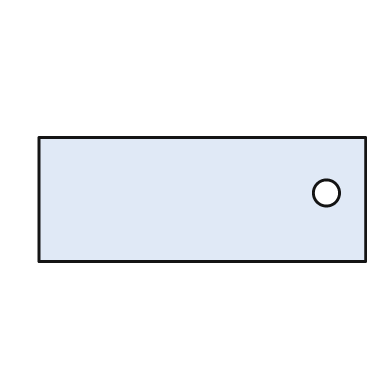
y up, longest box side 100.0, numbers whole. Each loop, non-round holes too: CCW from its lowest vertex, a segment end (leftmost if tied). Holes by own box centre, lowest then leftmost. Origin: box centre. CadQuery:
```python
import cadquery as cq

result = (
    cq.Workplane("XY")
    .moveTo(-50.0, -19.0)
    .lineTo(50.0, -19.0)
    .lineTo(50.0, 19.0)
    .lineTo(-50.0, 19.0)
    .close()
    .moveTo(38.0, 2.0)
    .circle(4.0)
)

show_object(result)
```